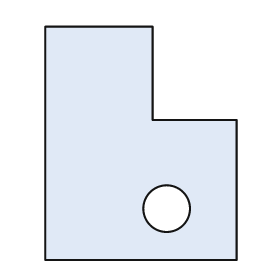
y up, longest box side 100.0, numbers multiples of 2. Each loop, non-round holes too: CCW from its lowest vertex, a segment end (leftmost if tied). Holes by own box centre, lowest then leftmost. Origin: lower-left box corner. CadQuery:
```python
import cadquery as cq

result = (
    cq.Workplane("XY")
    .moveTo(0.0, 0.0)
    .lineTo(82.0, 0.0)
    .lineTo(82.0, 60.0)
    .lineTo(46.0, 60.0)
    .lineTo(46.0, 100.0)
    .lineTo(0.0, 100.0)
    .close()
    .moveTo(52.0, 22.0)
    .circle(10.0)
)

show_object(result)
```